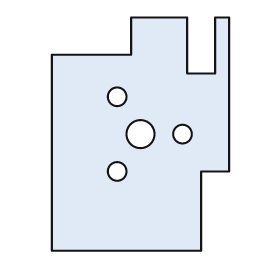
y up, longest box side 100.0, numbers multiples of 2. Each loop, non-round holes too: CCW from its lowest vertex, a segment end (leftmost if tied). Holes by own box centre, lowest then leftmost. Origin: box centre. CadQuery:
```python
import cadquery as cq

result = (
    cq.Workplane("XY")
    .moveTo(-38.0, -50.0)
    .lineTo(26.0, -50.0)
    .lineTo(26.0, -16.0)
    .lineTo(38.0, -16.0)
    .lineTo(38.0, 50.0)
    .lineTo(32.0, 50.0)
    .lineTo(32.0, 26.0)
    .lineTo(20.0, 26.0)
    .lineTo(20.0, 50.0)
    .lineTo(-4.0, 50.0)
    .lineTo(-4.0, 34.0)
    .lineTo(-38.0, 34.0)
    .close()
    .moveTo(-10.0, -16.0)
    .circle(4.0)
    .moveTo(0.0, 0.0)
    .circle(6.0)
    .moveTo(18.0, 0.0)
    .circle(4.0)
    .moveTo(-10.0, 16.0)
    .circle(4.0)
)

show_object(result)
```